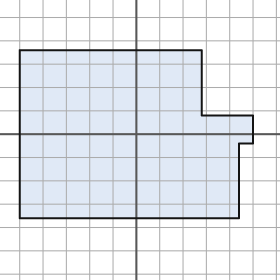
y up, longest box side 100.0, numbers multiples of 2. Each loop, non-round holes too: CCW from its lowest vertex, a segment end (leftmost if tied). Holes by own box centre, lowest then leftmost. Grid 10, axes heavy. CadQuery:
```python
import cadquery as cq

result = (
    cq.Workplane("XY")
    .moveTo(-50.0, -36.0)
    .lineTo(44.0, -36.0)
    .lineTo(44.0, -4.0)
    .lineTo(50.0, -4.0)
    .lineTo(50.0, 8.0)
    .lineTo(28.0, 8.0)
    .lineTo(28.0, 36.0)
    .lineTo(-50.0, 36.0)
    .close()
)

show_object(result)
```